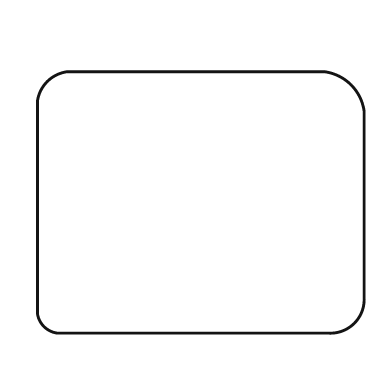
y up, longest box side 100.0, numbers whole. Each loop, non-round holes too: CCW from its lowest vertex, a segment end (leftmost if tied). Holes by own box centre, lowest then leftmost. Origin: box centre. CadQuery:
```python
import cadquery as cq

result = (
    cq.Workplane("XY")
    .moveTo(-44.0, -40.0)
    .lineTo(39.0, -40.0)
    .threePointArc((47.0, -37.0), (50.0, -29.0))
    .lineTo(50.0, 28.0)
    .threePointArc((46.0, 36.0), (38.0, 40.0))
    .lineTo(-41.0, 40.0)
    .threePointArc((-47.0, 37.0), (-50.0, 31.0))
    .lineTo(-50.0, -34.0)
    .threePointArc((-48.0, -38.0), (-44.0, -40.0))
    .close()
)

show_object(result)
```